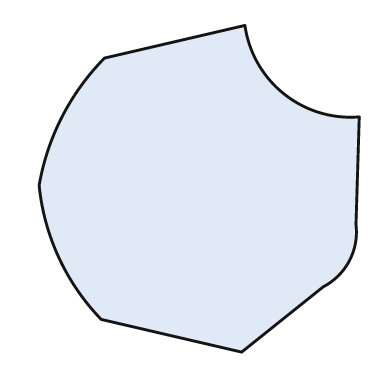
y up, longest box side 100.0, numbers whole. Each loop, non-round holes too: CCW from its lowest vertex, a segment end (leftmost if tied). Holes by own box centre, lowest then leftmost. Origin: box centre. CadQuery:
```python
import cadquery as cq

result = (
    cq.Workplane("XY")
    .moveTo(13.0, -50.0)
    .lineTo(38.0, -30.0)
    .threePointArc((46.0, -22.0), (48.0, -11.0))
    .lineTo(49.0, 22.0)
    .threePointArc((26.0, 29.0), (14.0, 50.0))
    .lineTo(-29.0, 40.0)
    .threePointArc((-42.0, 22.0), (-49.0, 1.0))
    .threePointArc((-43.0, -21.0), (-30.0, -40.0))
    .close()
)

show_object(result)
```